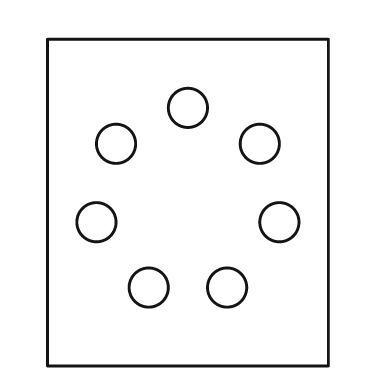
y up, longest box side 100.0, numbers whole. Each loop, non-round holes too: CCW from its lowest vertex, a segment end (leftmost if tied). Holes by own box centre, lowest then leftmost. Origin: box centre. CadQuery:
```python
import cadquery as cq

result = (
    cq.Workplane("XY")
    .moveTo(-43.0, -50.0)
    .lineTo(43.0, -50.0)
    .lineTo(43.0, 50.0)
    .lineTo(-43.0, 50.0)
    .close()
    .moveTo(-12.0, -26.0)
    .circle(6.0)
    .moveTo(12.0, -26.0)
    .circle(6.0)
    .moveTo(-28.0, -6.0)
    .circle(6.0)
    .moveTo(28.0, -6.0)
    .circle(6.0)
    .moveTo(-22.0, 18.0)
    .circle(6.0)
    .moveTo(22.0, 18.0)
    .circle(6.0)
    .moveTo(0.0, 29.0)
    .circle(6.0)
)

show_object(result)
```